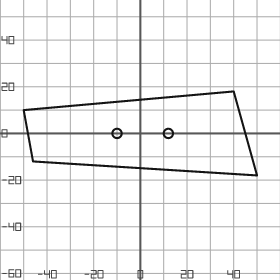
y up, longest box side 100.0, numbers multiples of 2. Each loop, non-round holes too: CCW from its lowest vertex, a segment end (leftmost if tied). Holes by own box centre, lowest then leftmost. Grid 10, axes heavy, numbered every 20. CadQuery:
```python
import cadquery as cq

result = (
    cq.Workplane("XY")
    .moveTo(50.0, -18.0)
    .lineTo(40.0, 18.0)
    .lineTo(-50.0, 10.0)
    .lineTo(-46.0, -12.0)
    .close()
    .moveTo(-10.0, 0.0)
    .circle(2.0)
    .moveTo(12.0, 0.0)
    .circle(2.0)
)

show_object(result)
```